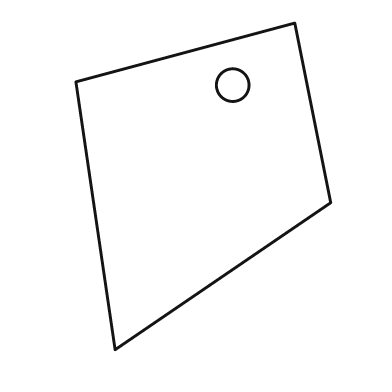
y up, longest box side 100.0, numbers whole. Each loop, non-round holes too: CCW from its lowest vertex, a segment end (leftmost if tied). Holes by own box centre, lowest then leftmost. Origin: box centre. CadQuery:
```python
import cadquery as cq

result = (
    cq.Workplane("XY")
    .moveTo(-27.0, -50.0)
    .lineTo(39.0, -5.0)
    .lineTo(28.0, 50.0)
    .lineTo(-39.0, 32.0)
    .close()
    .moveTo(9.0, 31.0)
    .circle(5.0)
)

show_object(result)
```